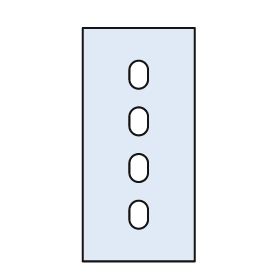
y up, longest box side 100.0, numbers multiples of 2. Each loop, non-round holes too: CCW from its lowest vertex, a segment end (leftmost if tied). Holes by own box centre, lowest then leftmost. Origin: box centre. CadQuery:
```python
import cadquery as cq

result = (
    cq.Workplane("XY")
    .moveTo(-24.0, -50.0)
    .lineTo(24.0, -50.0)
    .lineTo(24.0, 50.0)
    .lineTo(-24.0, 50.0)
    .close()
    .moveTo(-4.0, -32.0)
    .threePointArc((0.0, -36.0), (4.0, -32.0))
    .lineTo(4.0, -28.0)
    .threePointArc((0.0, -24.0), (-4.0, -28.0))
    .close()
    .moveTo(-4.0, -12.0)
    .threePointArc((0.0, -16.0), (4.0, -12.0))
    .lineTo(4.0, -8.0)
    .threePointArc((0.0, -4.0), (-4.0, -8.0))
    .close()
    .moveTo(-4.0, 8.0)
    .threePointArc((0.0, 4.0), (4.0, 8.0))
    .lineTo(4.0, 12.0)
    .threePointArc((0.0, 16.0), (-4.0, 12.0))
    .close()
    .moveTo(-4.0, 28.0)
    .threePointArc((0.0, 24.0), (4.0, 28.0))
    .lineTo(4.0, 32.0)
    .threePointArc((0.0, 36.0), (-4.0, 32.0))
    .close()
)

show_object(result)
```